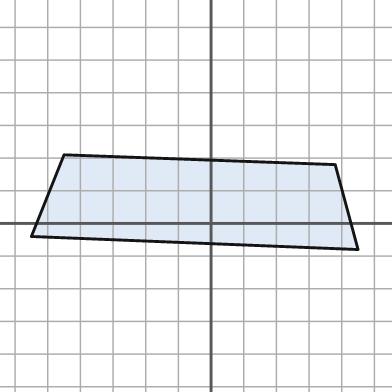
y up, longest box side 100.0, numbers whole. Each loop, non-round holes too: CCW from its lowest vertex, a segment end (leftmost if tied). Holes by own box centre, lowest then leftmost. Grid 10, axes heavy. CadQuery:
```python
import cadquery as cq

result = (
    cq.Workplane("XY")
    .moveTo(45.0, -8.0)
    .lineTo(38.0, 18.0)
    .lineTo(-45.0, 21.0)
    .lineTo(-55.0, -4.0)
    .close()
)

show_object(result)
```